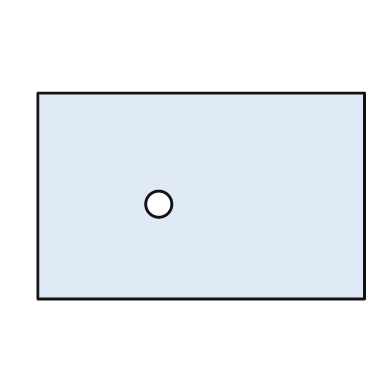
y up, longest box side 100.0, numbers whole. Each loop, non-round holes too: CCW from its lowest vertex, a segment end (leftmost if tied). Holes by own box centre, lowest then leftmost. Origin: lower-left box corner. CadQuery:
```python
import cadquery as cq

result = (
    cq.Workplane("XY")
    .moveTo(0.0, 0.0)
    .lineTo(100.0, 0.0)
    .lineTo(100.0, 63.0)
    .lineTo(0.0, 63.0)
    .close()
    .moveTo(37.0, 29.0)
    .circle(4.0)
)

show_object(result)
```